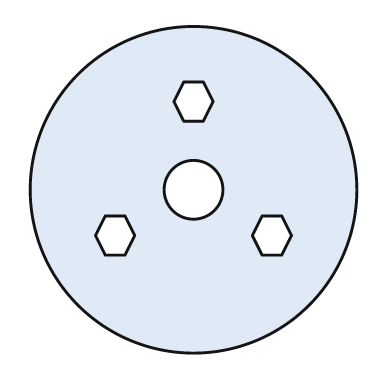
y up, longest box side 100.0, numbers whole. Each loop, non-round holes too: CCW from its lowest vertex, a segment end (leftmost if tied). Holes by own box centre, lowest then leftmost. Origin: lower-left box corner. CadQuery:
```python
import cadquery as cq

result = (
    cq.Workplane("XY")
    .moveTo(50.0, 50.0)
    .circle(50.0)
    .moveTo(23.0, 30.0)
    .lineTo(29.0, 30.0)
    .lineTo(32.0, 36.0)
    .lineTo(29.0, 42.0)
    .lineTo(23.0, 42.0)
    .lineTo(20.0, 36.0)
    .close()
    .moveTo(71.0, 30.0)
    .lineTo(77.0, 30.0)
    .lineTo(80.0, 36.0)
    .lineTo(77.0, 42.0)
    .lineTo(71.0, 42.0)
    .lineTo(68.0, 36.0)
    .close()
    .moveTo(50.0, 50.0)
    .circle(9.0)
    .moveTo(47.0, 71.0)
    .lineTo(53.0, 71.0)
    .lineTo(56.0, 77.0)
    .lineTo(53.0, 83.0)
    .lineTo(47.0, 83.0)
    .lineTo(44.0, 77.0)
    .close()
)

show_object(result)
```